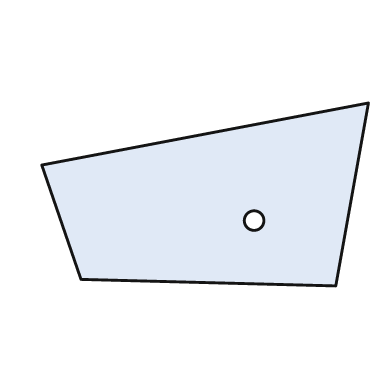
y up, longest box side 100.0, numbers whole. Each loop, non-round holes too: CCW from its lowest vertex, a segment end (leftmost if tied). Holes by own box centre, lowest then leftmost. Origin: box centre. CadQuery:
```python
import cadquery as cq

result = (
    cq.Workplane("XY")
    .moveTo(40.0, -28.0)
    .lineTo(50.0, 28.0)
    .lineTo(-50.0, 9.0)
    .lineTo(-38.0, -26.0)
    .close()
    .moveTo(15.0, -8.0)
    .circle(3.0)
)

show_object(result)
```